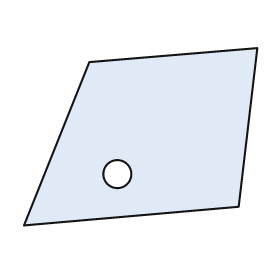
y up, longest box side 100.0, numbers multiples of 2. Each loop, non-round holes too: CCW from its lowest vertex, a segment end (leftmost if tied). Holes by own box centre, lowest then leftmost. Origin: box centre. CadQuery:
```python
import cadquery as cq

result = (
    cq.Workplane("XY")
    .moveTo(-50.0, -38.0)
    .lineTo(42.0, -30.0)
    .lineTo(50.0, 38.0)
    .lineTo(-22.0, 32.0)
    .close()
    .moveTo(-10.0, -16.0)
    .circle(6.0)
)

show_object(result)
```